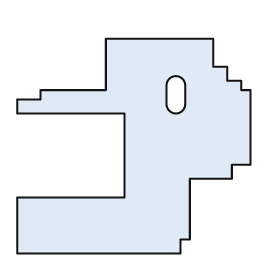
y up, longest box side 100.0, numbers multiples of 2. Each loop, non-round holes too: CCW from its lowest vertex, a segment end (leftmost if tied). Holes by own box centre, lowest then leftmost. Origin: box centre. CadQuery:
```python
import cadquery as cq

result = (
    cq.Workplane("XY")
    .moveTo(-50.0, -46.0)
    .lineTo(20.0, -46.0)
    .lineTo(20.0, -40.0)
    .lineTo(24.0, -40.0)
    .lineTo(24.0, -14.0)
    .lineTo(42.0, -14.0)
    .lineTo(42.0, -8.0)
    .lineTo(50.0, -8.0)
    .lineTo(50.0, 24.0)
    .lineTo(46.0, 24.0)
    .lineTo(46.0, 28.0)
    .lineTo(40.0, 28.0)
    .lineTo(40.0, 34.0)
    .lineTo(34.0, 34.0)
    .lineTo(34.0, 46.0)
    .lineTo(-12.0, 46.0)
    .lineTo(-12.0, 24.0)
    .lineTo(-40.0, 24.0)
    .lineTo(-40.0, 20.0)
    .lineTo(-50.0, 20.0)
    .lineTo(-50.0, 14.0)
    .lineTo(-4.0, 14.0)
    .lineTo(-4.0, -22.0)
    .lineTo(-50.0, -22.0)
    .close()
    .moveTo(14.0, 18.0)
    .threePointArc((18.0, 14.0), (22.0, 18.0))
    .lineTo(22.0, 26.0)
    .threePointArc((18.0, 30.0), (14.0, 26.0))
    .close()
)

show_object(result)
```